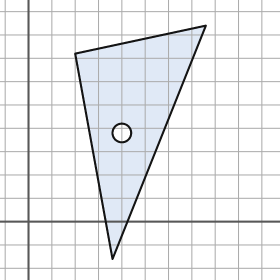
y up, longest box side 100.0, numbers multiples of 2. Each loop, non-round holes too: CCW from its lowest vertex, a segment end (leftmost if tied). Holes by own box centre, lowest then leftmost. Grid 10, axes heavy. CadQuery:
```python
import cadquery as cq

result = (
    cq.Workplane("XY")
    .moveTo(36.0, -16.0)
    .lineTo(76.0, 84.0)
    .lineTo(20.0, 72.0)
    .close()
    .moveTo(40.0, 38.0)
    .circle(4.0)
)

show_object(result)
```